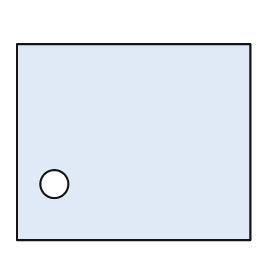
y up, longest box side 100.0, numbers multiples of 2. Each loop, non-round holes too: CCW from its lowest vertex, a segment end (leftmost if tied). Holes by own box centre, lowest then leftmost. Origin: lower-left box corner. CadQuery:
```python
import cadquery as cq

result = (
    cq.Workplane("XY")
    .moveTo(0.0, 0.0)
    .lineTo(100.0, 0.0)
    .lineTo(100.0, 84.0)
    .lineTo(0.0, 84.0)
    .close()
    .moveTo(16.0, 24.0)
    .circle(6.0)
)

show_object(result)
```